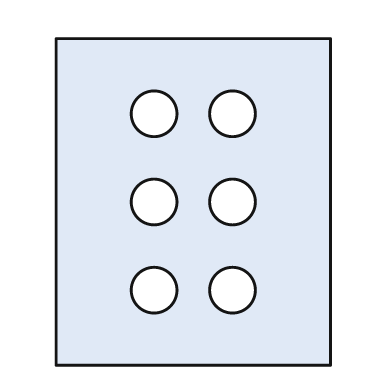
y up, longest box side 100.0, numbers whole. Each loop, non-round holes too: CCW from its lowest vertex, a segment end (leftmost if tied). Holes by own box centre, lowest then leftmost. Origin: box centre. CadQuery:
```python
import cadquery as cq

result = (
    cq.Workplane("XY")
    .moveTo(-42.0, -50.0)
    .lineTo(42.0, -50.0)
    .lineTo(42.0, 50.0)
    .lineTo(-42.0, 50.0)
    .close()
    .moveTo(-12.0, -27.0)
    .circle(7.0)
    .moveTo(12.0, -27.0)
    .circle(7.0)
    .moveTo(-12.0, 0.0)
    .circle(7.0)
    .moveTo(12.0, 0.0)
    .circle(7.0)
    .moveTo(-12.0, 27.0)
    .circle(7.0)
    .moveTo(12.0, 27.0)
    .circle(7.0)
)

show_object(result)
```